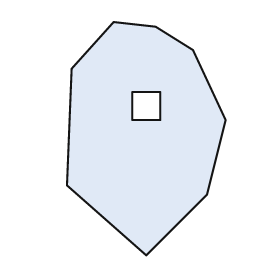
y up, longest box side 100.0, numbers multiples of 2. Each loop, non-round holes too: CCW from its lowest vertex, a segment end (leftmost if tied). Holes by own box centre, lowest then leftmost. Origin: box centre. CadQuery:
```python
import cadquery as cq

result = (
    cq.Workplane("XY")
    .moveTo(0.0, -50.0)
    .lineTo(26.0, -24.0)
    .lineTo(34.0, 8.0)
    .lineTo(20.0, 38.0)
    .lineTo(4.0, 48.0)
    .lineTo(-14.0, 50.0)
    .lineTo(-32.0, 30.0)
    .lineTo(-34.0, -20.0)
    .close()
    .moveTo(-6.0, 8.0)
    .lineTo(6.0, 8.0)
    .lineTo(6.0, 20.0)
    .lineTo(-6.0, 20.0)
    .close()
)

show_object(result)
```